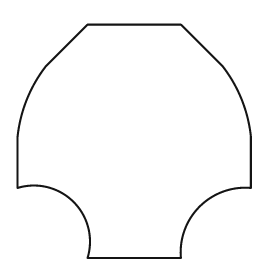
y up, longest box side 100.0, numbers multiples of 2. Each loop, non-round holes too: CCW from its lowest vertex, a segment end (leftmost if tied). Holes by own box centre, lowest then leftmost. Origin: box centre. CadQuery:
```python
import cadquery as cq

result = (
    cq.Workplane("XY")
    .moveTo(-20.0, -50.0)
    .lineTo(20.0, -50.0)
    .threePointArc((28.0, -28.0), (50.0, -20.0))
    .lineTo(50.0, 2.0)
    .threePointArc((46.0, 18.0), (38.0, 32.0))
    .lineTo(20.0, 50.0)
    .lineTo(-20.0, 50.0)
    .lineTo(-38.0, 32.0)
    .threePointArc((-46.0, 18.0), (-50.0, 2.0))
    .lineTo(-50.0, -20.0)
    .threePointArc((-26.0, -26.0), (-20.0, -50.0))
    .close()
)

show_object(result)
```